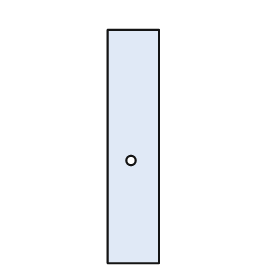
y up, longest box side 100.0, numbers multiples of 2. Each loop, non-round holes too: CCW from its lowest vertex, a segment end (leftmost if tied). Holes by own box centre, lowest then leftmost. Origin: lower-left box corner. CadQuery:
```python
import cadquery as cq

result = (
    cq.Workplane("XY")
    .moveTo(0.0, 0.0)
    .lineTo(22.0, 0.0)
    .lineTo(22.0, 100.0)
    .lineTo(0.0, 100.0)
    .close()
    .moveTo(10.0, 44.0)
    .circle(2.0)
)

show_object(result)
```